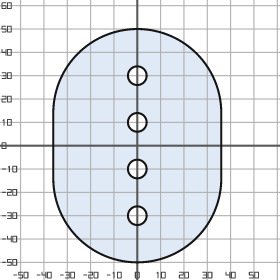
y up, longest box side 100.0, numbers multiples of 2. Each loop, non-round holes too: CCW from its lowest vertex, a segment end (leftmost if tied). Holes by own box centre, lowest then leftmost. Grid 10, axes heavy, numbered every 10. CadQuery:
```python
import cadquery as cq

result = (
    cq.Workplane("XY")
    .moveTo(-36.0, -14.0)
    .threePointArc((0.0, -50.0), (36.0, -14.0))
    .lineTo(36.0, 14.0)
    .threePointArc((0.0, 50.0), (-36.0, 14.0))
    .close()
    .moveTo(0.0, -30.0)
    .circle(4.0)
    .moveTo(0.0, -10.0)
    .circle(4.0)
    .moveTo(0.0, 10.0)
    .circle(4.0)
    .moveTo(0.0, 30.0)
    .circle(4.0)
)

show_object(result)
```